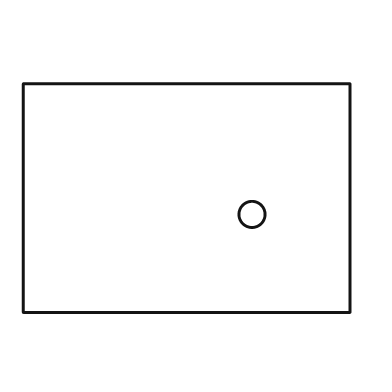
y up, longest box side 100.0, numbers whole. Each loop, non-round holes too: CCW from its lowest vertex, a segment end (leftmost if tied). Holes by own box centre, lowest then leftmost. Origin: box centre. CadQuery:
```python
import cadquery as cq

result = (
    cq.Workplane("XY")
    .moveTo(-50.0, -35.0)
    .lineTo(50.0, -35.0)
    .lineTo(50.0, 35.0)
    .lineTo(-50.0, 35.0)
    .close()
    .moveTo(20.0, -5.0)
    .circle(4.0)
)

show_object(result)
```